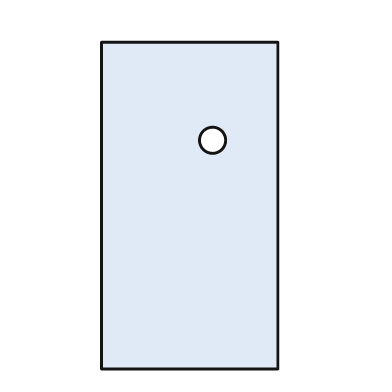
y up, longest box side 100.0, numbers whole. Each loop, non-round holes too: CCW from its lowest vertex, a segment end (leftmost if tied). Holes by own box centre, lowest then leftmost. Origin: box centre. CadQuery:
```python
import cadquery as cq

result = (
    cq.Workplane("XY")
    .moveTo(-27.0, -50.0)
    .lineTo(27.0, -50.0)
    .lineTo(27.0, 50.0)
    .lineTo(-27.0, 50.0)
    .close()
    .moveTo(7.0, 20.0)
    .circle(4.0)
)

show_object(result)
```